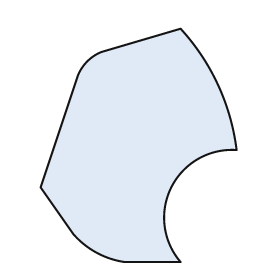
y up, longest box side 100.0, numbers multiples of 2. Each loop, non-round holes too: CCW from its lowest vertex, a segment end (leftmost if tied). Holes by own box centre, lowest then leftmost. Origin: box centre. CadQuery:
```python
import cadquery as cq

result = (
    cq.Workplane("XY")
    .moveTo(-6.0, -50.0)
    .lineTo(18.0, -50.0)
    .threePointArc((14.0, -18.0), (42.0, -2.0))
    .threePointArc((34.0, 26.0), (18.0, 50.0))
    .lineTo(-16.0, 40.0)
    .threePointArc((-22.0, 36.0), (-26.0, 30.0))
    .lineTo(-42.0, -18.0)
    .lineTo(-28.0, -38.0)
    .threePointArc((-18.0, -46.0), (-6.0, -50.0))
    .close()
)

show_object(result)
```